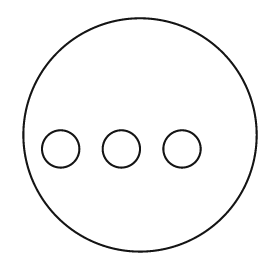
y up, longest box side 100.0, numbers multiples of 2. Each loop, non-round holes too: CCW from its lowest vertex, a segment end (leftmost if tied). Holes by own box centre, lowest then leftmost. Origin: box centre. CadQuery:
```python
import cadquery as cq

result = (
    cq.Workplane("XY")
    .moveTo(0.0, 0.0)
    .circle(50.0)
    .moveTo(-34.0, -6.0)
    .circle(8.0)
    .moveTo(-8.0, -6.0)
    .circle(8.0)
    .moveTo(18.0, -6.0)
    .circle(8.0)
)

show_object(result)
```